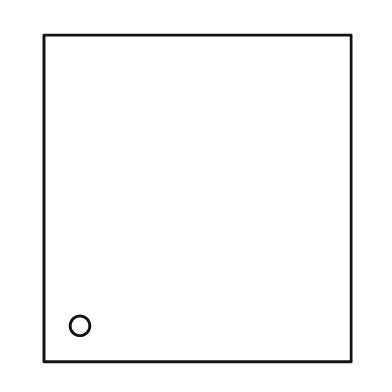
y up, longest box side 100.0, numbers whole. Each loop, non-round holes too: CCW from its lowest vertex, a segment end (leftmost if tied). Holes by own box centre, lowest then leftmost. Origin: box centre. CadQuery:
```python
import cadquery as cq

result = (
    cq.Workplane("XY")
    .moveTo(-47.0, -50.0)
    .lineTo(47.0, -50.0)
    .lineTo(47.0, 50.0)
    .lineTo(-47.0, 50.0)
    .close()
    .moveTo(-36.0, -39.0)
    .circle(3.0)
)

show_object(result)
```